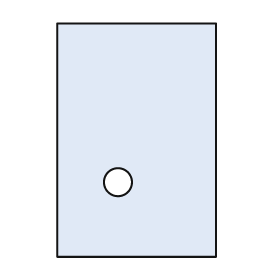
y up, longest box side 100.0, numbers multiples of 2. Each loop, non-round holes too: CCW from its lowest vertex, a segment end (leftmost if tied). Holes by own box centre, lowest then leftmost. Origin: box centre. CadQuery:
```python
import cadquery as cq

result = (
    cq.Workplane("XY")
    .moveTo(-34.0, -50.0)
    .lineTo(34.0, -50.0)
    .lineTo(34.0, 50.0)
    .lineTo(-34.0, 50.0)
    .close()
    .moveTo(-8.0, -18.0)
    .circle(6.0)
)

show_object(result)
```